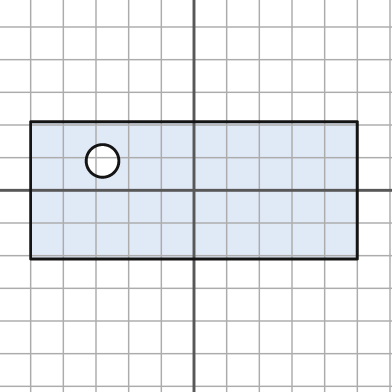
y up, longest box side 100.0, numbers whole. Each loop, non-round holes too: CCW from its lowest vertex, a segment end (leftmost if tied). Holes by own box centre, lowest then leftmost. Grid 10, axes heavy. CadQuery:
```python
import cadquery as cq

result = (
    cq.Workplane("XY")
    .moveTo(-50.0, -21.0)
    .lineTo(50.0, -21.0)
    .lineTo(50.0, 21.0)
    .lineTo(-50.0, 21.0)
    .close()
    .moveTo(-28.0, 9.0)
    .circle(5.0)
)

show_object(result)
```